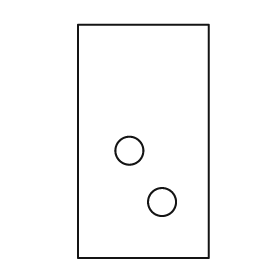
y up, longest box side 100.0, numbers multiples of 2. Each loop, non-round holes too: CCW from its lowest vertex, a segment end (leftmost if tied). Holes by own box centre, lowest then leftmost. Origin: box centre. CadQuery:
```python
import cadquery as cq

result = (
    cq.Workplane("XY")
    .moveTo(-28.0, -50.0)
    .lineTo(28.0, -50.0)
    .lineTo(28.0, 50.0)
    .lineTo(-28.0, 50.0)
    .close()
    .moveTo(8.0, -26.0)
    .circle(6.0)
    .moveTo(-6.0, -4.0)
    .circle(6.0)
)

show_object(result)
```